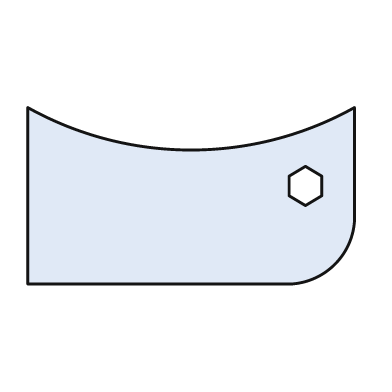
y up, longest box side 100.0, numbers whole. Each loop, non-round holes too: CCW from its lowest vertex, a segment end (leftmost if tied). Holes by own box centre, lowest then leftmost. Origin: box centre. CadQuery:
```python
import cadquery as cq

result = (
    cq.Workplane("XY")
    .moveTo(-50.0, -27.0)
    .lineTo(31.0, -27.0)
    .threePointArc((44.0, -21.0), (50.0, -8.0))
    .lineTo(50.0, 27.0)
    .threePointArc((0.0, 14.0), (-50.0, 27.0))
    .close()
    .moveTo(35.0, -3.0)
    .lineTo(40.0, 0.0)
    .lineTo(40.0, 6.0)
    .lineTo(35.0, 9.0)
    .lineTo(30.0, 6.0)
    .lineTo(30.0, 0.0)
    .close()
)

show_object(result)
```